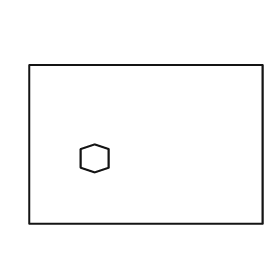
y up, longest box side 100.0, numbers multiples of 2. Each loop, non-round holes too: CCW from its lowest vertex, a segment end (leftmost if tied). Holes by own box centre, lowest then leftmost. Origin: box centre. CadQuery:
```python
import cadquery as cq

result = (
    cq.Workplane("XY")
    .moveTo(-50.0, -34.0)
    .lineTo(50.0, -34.0)
    .lineTo(50.0, 34.0)
    .lineTo(-50.0, 34.0)
    .close()
    .moveTo(-22.0, -12.0)
    .lineTo(-16.0, -10.0)
    .lineTo(-16.0, -2.0)
    .lineTo(-22.0, 0.0)
    .lineTo(-28.0, -2.0)
    .lineTo(-28.0, -10.0)
    .close()
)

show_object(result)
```